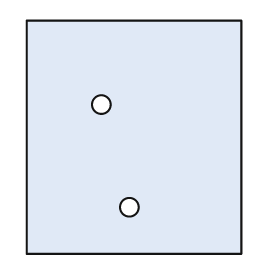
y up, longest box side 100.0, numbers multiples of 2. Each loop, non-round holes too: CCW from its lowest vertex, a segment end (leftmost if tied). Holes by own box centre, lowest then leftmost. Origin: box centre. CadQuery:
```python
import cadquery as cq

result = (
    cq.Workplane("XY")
    .moveTo(-46.0, -50.0)
    .lineTo(46.0, -50.0)
    .lineTo(46.0, 50.0)
    .lineTo(-46.0, 50.0)
    .close()
    .moveTo(-2.0, -30.0)
    .circle(4.0)
    .moveTo(-14.0, 14.0)
    .circle(4.0)
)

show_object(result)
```